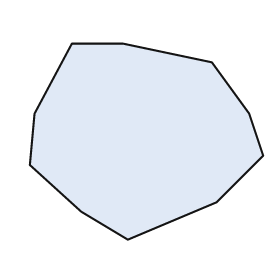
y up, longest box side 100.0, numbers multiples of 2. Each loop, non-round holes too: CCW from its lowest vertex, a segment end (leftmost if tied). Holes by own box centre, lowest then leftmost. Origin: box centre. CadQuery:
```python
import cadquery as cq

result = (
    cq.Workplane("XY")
    .moveTo(-8.0, -42.0)
    .lineTo(30.0, -26.0)
    .lineTo(50.0, -6.0)
    .lineTo(44.0, 12.0)
    .lineTo(28.0, 34.0)
    .lineTo(-10.0, 42.0)
    .lineTo(-32.0, 42.0)
    .lineTo(-48.0, 12.0)
    .lineTo(-50.0, -10.0)
    .lineTo(-28.0, -30.0)
    .close()
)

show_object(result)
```